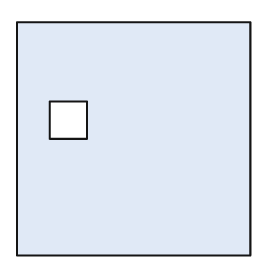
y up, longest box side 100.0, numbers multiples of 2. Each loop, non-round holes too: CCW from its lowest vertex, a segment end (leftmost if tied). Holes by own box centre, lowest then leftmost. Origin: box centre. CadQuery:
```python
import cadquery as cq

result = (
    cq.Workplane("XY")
    .moveTo(-50.0, -50.0)
    .lineTo(50.0, -50.0)
    .lineTo(50.0, 50.0)
    .lineTo(-50.0, 50.0)
    .close()
    .moveTo(-36.0, 0.0)
    .lineTo(-20.0, 0.0)
    .lineTo(-20.0, 16.0)
    .lineTo(-36.0, 16.0)
    .close()
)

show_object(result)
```